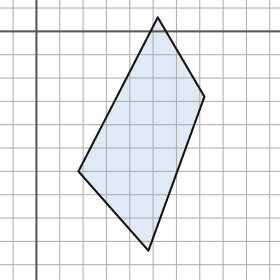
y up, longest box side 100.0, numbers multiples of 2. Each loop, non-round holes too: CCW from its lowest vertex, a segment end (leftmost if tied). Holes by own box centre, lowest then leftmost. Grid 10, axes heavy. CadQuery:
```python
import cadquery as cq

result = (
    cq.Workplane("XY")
    .moveTo(48.0, -94.0)
    .lineTo(72.0, -28.0)
    .lineTo(52.0, 6.0)
    .lineTo(18.0, -60.0)
    .close()
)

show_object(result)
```